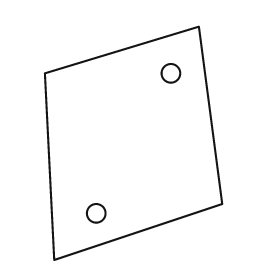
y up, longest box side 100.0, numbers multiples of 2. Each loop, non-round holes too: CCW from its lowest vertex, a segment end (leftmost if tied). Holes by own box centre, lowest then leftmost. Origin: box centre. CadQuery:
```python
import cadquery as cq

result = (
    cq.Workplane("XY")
    .moveTo(-34.0, -50.0)
    .lineTo(38.0, -26.0)
    .lineTo(28.0, 50.0)
    .lineTo(-38.0, 30.0)
    .close()
    .moveTo(-16.0, -30.0)
    .circle(4.0)
    .moveTo(16.0, 30.0)
    .circle(4.0)
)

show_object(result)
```